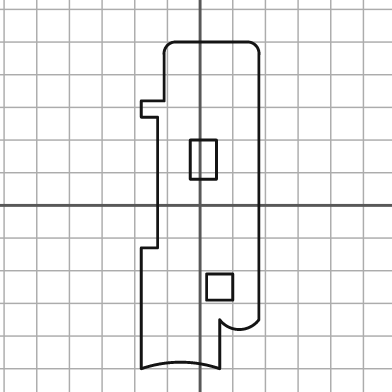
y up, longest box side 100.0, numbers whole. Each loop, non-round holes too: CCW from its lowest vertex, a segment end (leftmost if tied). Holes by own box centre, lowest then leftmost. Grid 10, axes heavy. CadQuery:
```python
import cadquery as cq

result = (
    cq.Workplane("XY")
    .moveTo(-18.0, -50.0)
    .threePointArc((-6.0, -48.0), (6.0, -50.0))
    .lineTo(6.0, -35.0)
    .threePointArc((12.0, -38.0), (18.0, -35.0))
    .lineTo(18.0, 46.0)
    .threePointArc((17.0, 49.0), (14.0, 50.0))
    .lineTo(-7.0, 50.0)
    .threePointArc((-10.0, 49.0), (-11.0, 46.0))
    .lineTo(-11.0, 32.0)
    .lineTo(-18.0, 32.0)
    .lineTo(-18.0, 27.0)
    .lineTo(-13.0, 27.0)
    .lineTo(-13.0, -13.0)
    .lineTo(-18.0, -13.0)
    .close()
    .moveTo(2.0, -29.0)
    .lineTo(10.0, -29.0)
    .lineTo(10.0, -21.0)
    .lineTo(2.0, -21.0)
    .close()
    .moveTo(-3.0, 8.0)
    .lineTo(5.0, 8.0)
    .lineTo(5.0, 20.0)
    .lineTo(-3.0, 20.0)
    .close()
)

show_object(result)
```